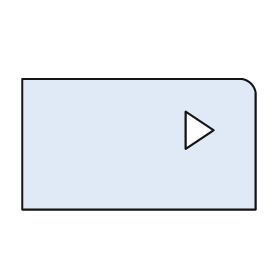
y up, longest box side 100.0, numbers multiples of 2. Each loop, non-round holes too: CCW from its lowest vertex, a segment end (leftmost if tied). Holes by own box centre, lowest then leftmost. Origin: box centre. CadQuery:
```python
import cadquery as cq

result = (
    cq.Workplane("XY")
    .moveTo(-50.0, -28.0)
    .lineTo(50.0, -28.0)
    .lineTo(50.0, 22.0)
    .threePointArc((48.0, 26.0), (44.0, 28.0))
    .lineTo(-50.0, 28.0)
    .close()
    .moveTo(20.0, -2.0)
    .lineTo(32.0, 6.0)
    .lineTo(20.0, 14.0)
    .close()
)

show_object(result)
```